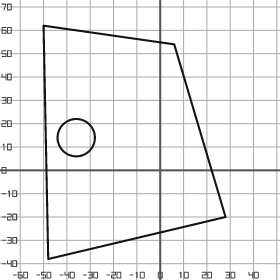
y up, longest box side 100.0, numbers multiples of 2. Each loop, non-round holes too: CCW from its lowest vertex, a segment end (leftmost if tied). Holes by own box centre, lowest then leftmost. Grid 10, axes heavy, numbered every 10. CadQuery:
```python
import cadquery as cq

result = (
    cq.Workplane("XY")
    .moveTo(-48.0, -38.0)
    .lineTo(28.0, -20.0)
    .lineTo(6.0, 54.0)
    .lineTo(-50.0, 62.0)
    .close()
    .moveTo(-36.0, 14.0)
    .circle(8.0)
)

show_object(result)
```